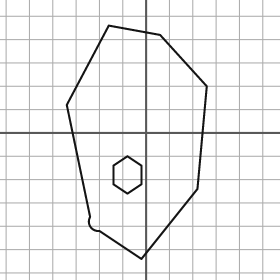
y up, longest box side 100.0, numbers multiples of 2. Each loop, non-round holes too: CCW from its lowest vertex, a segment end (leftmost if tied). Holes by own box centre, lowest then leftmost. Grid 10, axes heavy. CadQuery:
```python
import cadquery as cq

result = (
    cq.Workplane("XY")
    .moveTo(-2.0, -54.0)
    .lineTo(22.0, -24.0)
    .lineTo(26.0, 20.0)
    .lineTo(6.0, 42.0)
    .lineTo(-16.0, 46.0)
    .lineTo(-34.0, 12.0)
    .lineTo(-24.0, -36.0)
    .threePointArc((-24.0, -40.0), (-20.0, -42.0))
    .close()
    .moveTo(-8.0, -26.0)
    .lineTo(-2.0, -22.0)
    .lineTo(-2.0, -14.0)
    .lineTo(-8.0, -10.0)
    .lineTo(-14.0, -14.0)
    .lineTo(-14.0, -22.0)
    .close()
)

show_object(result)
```